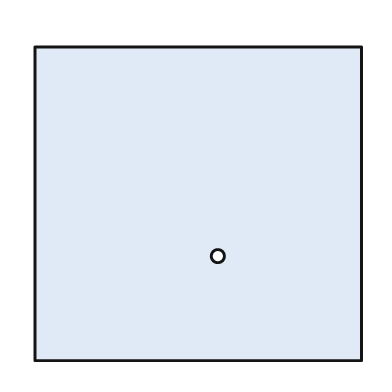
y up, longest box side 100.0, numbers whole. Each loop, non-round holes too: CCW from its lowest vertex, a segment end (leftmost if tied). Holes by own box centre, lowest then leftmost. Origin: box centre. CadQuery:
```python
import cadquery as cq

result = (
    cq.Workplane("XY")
    .moveTo(-50.0, -48.0)
    .lineTo(50.0, -48.0)
    .lineTo(50.0, 48.0)
    .lineTo(-50.0, 48.0)
    .close()
    .moveTo(6.0, -16.0)
    .circle(2.0)
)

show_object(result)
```